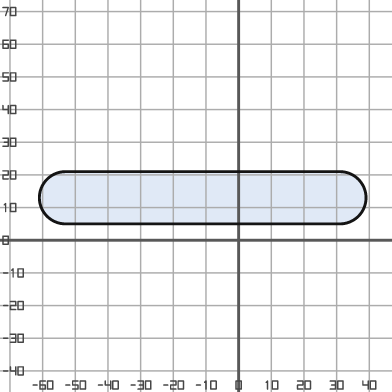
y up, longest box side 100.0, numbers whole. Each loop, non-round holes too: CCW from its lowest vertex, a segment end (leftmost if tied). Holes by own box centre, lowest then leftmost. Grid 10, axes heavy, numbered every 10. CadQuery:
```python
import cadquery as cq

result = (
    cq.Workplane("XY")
    .moveTo(-53.0, 5.0)
    .lineTo(31.0, 5.0)
    .threePointArc((39.0, 13.0), (31.0, 21.0))
    .lineTo(-53.0, 21.0)
    .threePointArc((-61.0, 13.0), (-53.0, 5.0))
    .close()
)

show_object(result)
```